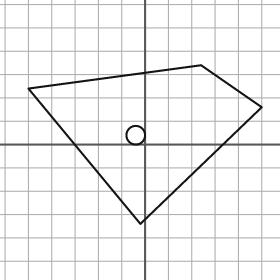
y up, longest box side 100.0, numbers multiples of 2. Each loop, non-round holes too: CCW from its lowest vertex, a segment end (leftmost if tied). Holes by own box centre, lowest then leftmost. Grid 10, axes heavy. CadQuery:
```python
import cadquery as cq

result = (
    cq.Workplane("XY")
    .moveTo(-2.0, -34.0)
    .lineTo(50.0, 16.0)
    .lineTo(24.0, 34.0)
    .lineTo(-50.0, 24.0)
    .close()
    .moveTo(-4.0, 4.0)
    .circle(4.0)
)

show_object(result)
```